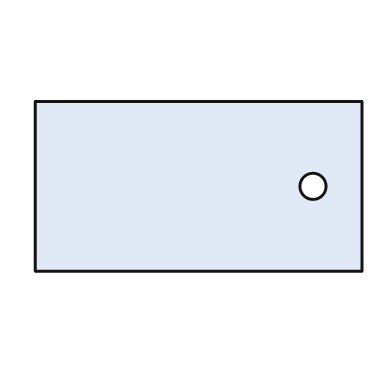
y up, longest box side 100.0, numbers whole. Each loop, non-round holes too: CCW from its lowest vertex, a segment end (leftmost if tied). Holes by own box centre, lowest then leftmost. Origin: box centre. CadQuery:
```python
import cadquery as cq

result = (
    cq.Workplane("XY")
    .moveTo(-50.0, -26.0)
    .lineTo(50.0, -26.0)
    .lineTo(50.0, 26.0)
    .lineTo(-50.0, 26.0)
    .close()
    .moveTo(35.0, 0.0)
    .circle(4.0)
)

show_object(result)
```